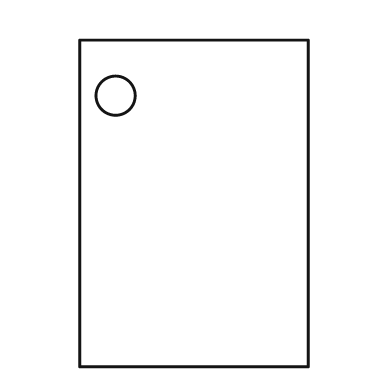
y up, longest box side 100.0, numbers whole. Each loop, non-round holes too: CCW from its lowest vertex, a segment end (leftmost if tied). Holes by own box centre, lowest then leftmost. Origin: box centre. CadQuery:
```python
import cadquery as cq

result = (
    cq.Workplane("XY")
    .moveTo(-35.0, -50.0)
    .lineTo(35.0, -50.0)
    .lineTo(35.0, 50.0)
    .lineTo(-35.0, 50.0)
    .close()
    .moveTo(-24.0, 33.0)
    .circle(6.0)
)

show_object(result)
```